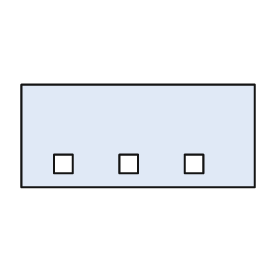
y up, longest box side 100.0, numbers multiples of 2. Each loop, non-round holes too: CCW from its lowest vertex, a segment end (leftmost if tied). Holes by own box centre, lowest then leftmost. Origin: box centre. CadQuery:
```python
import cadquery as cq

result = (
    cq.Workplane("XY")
    .moveTo(-50.0, -22.0)
    .lineTo(50.0, -22.0)
    .lineTo(50.0, 22.0)
    .lineTo(-50.0, 22.0)
    .close()
    .moveTo(-36.0, -16.0)
    .lineTo(-28.0, -16.0)
    .lineTo(-28.0, -8.0)
    .lineTo(-36.0, -8.0)
    .close()
    .moveTo(-8.0, -16.0)
    .lineTo(0.0, -16.0)
    .lineTo(0.0, -8.0)
    .lineTo(-8.0, -8.0)
    .close()
    .moveTo(20.0, -16.0)
    .lineTo(28.0, -16.0)
    .lineTo(28.0, -8.0)
    .lineTo(20.0, -8.0)
    .close()
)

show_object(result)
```